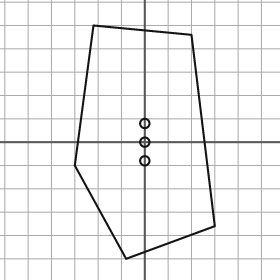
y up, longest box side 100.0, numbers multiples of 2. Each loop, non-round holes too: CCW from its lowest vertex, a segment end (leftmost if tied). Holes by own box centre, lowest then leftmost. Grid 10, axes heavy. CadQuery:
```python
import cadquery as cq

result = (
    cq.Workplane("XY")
    .moveTo(-8.0, -50.0)
    .lineTo(30.0, -36.0)
    .lineTo(20.0, 46.0)
    .lineTo(-22.0, 50.0)
    .lineTo(-30.0, -10.0)
    .close()
    .moveTo(0.0, -8.0)
    .circle(2.0)
    .moveTo(0.0, 0.0)
    .circle(2.0)
    .moveTo(0.0, 8.0)
    .circle(2.0)
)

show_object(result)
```